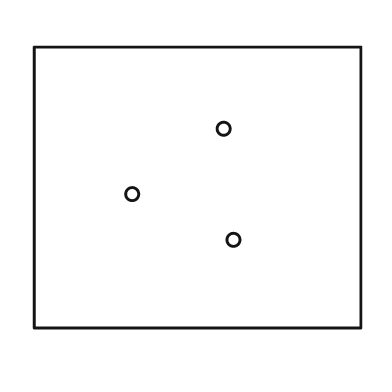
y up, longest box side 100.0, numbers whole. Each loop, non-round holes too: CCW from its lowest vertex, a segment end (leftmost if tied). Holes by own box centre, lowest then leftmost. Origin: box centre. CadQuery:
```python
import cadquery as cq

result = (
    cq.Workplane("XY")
    .moveTo(-50.0, -43.0)
    .lineTo(50.0, -43.0)
    .lineTo(50.0, 43.0)
    .lineTo(-50.0, 43.0)
    .close()
    .moveTo(11.0, -16.0)
    .circle(2.0)
    .moveTo(-20.0, -2.0)
    .circle(2.0)
    .moveTo(8.0, 18.0)
    .circle(2.0)
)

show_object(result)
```